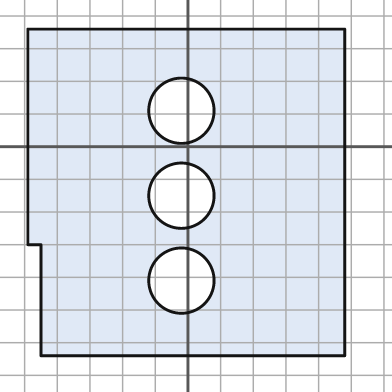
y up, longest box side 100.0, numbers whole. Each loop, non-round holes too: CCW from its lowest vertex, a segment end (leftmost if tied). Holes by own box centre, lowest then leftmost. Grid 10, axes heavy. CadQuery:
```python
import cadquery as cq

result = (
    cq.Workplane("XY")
    .moveTo(-45.0, -64.0)
    .lineTo(48.0, -64.0)
    .lineTo(48.0, 36.0)
    .lineTo(-49.0, 36.0)
    .lineTo(-49.0, -30.0)
    .lineTo(-45.0, -30.0)
    .close()
    .moveTo(-2.0, -41.0)
    .circle(10.0)
    .moveTo(-2.0, -15.0)
    .circle(10.0)
    .moveTo(-2.0, 11.0)
    .circle(10.0)
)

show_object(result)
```